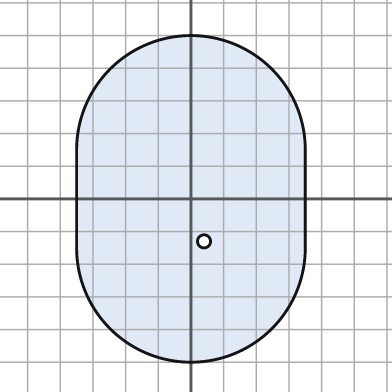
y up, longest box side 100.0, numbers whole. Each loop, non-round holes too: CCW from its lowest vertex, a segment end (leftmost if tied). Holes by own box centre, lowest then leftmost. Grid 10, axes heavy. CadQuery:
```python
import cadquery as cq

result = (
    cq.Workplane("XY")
    .moveTo(-35.0, -15.0)
    .threePointArc((0.0, -50.0), (35.0, -15.0))
    .lineTo(35.0, 15.0)
    .threePointArc((0.0, 50.0), (-35.0, 15.0))
    .close()
    .moveTo(4.0, -13.0)
    .circle(2.0)
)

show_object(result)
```